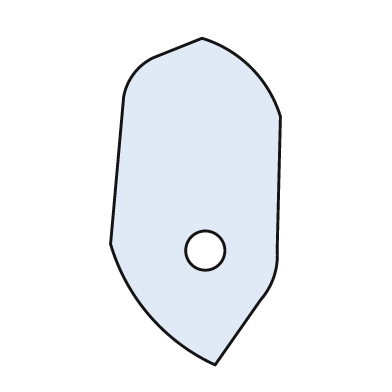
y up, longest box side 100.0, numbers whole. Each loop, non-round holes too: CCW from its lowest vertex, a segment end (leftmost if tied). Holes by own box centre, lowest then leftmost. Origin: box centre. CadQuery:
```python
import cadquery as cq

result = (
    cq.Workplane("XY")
    .moveTo(6.0, -50.0)
    .lineTo(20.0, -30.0)
    .threePointArc((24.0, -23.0), (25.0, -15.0))
    .lineTo(26.0, 26.0)
    .threePointArc((17.0, 41.0), (2.0, 50.0))
    .lineTo(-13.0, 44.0)
    .threePointArc((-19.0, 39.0), (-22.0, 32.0))
    .lineTo(-26.0, -13.0)
    .threePointArc((-14.0, -35.0), (6.0, -50.0))
    .close()
    .moveTo(3.0, -15.0)
    .circle(6.0)
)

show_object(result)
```